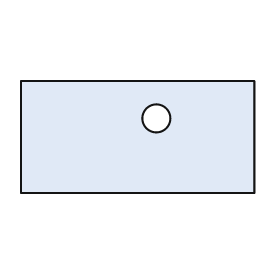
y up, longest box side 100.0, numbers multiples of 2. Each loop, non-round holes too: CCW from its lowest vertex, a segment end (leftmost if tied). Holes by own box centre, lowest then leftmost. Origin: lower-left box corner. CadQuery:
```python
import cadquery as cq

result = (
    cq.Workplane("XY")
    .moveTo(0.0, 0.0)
    .lineTo(100.0, 0.0)
    .lineTo(100.0, 48.0)
    .lineTo(0.0, 48.0)
    .close()
    .moveTo(58.0, 32.0)
    .circle(6.0)
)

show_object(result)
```